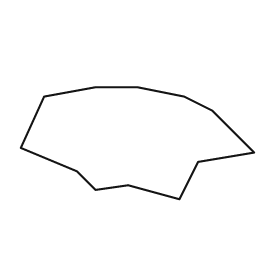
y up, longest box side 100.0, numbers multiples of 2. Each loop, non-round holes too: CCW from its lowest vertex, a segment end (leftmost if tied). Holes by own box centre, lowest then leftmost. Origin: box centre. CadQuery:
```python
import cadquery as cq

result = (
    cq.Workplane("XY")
    .moveTo(18.0, -24.0)
    .lineTo(26.0, -8.0)
    .lineTo(50.0, -4.0)
    .lineTo(32.0, 14.0)
    .lineTo(20.0, 20.0)
    .lineTo(0.0, 24.0)
    .lineTo(-18.0, 24.0)
    .lineTo(-40.0, 20.0)
    .lineTo(-50.0, -2.0)
    .lineTo(-26.0, -12.0)
    .lineTo(-18.0, -20.0)
    .lineTo(-4.0, -18.0)
    .close()
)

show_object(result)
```